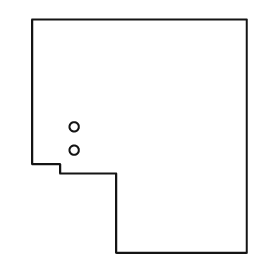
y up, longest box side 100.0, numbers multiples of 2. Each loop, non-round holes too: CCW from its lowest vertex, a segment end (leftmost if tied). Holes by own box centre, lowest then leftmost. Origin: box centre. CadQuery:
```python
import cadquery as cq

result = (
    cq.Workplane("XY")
    .moveTo(-10.0, -50.0)
    .lineTo(46.0, -50.0)
    .lineTo(46.0, 50.0)
    .lineTo(-46.0, 50.0)
    .lineTo(-46.0, -12.0)
    .lineTo(-34.0, -12.0)
    .lineTo(-34.0, -16.0)
    .lineTo(-10.0, -16.0)
    .close()
    .moveTo(-28.0, -6.0)
    .circle(2.0)
    .moveTo(-28.0, 4.0)
    .circle(2.0)
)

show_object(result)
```